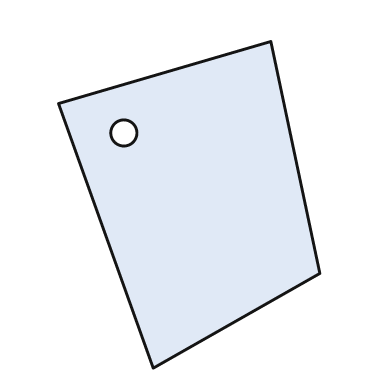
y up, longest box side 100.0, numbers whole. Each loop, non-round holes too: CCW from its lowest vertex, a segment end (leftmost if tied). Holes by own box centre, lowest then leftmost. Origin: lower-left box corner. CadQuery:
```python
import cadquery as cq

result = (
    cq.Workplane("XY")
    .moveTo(29.0, 0.0)
    .lineTo(80.0, 29.0)
    .lineTo(65.0, 100.0)
    .lineTo(0.0, 81.0)
    .close()
    .moveTo(20.0, 72.0)
    .circle(4.0)
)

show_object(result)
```